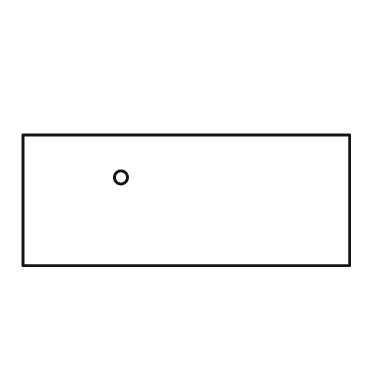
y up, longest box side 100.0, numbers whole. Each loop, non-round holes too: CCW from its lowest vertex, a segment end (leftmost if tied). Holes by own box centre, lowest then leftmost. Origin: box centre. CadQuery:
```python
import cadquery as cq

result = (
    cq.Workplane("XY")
    .moveTo(-50.0, -20.0)
    .lineTo(50.0, -20.0)
    .lineTo(50.0, 20.0)
    .lineTo(-50.0, 20.0)
    .close()
    .moveTo(-20.0, 7.0)
    .circle(2.0)
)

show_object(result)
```